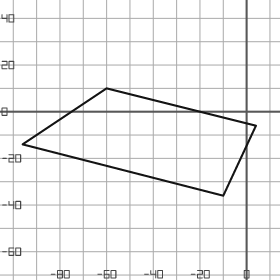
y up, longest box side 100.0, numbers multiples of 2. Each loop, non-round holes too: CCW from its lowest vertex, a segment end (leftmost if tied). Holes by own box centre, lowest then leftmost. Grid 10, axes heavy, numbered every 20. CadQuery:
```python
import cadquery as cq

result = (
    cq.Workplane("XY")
    .moveTo(-10.0, -36.0)
    .lineTo(4.0, -6.0)
    .lineTo(-60.0, 10.0)
    .lineTo(-96.0, -14.0)
    .close()
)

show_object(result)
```